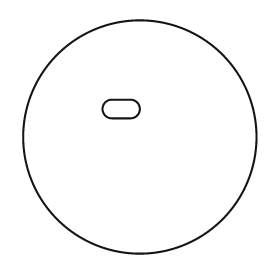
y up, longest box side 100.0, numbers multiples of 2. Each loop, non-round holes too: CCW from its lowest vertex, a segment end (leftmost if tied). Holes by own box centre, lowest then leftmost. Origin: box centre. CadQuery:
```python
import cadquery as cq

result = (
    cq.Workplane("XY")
    .moveTo(0.0, 0.0)
    .circle(50.0)
    .moveTo(-12.0, 8.0)
    .lineTo(-4.0, 8.0)
    .threePointArc((0.0, 12.0), (-4.0, 16.0))
    .lineTo(-12.0, 16.0)
    .threePointArc((-16.0, 12.0), (-12.0, 8.0))
    .close()
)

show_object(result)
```